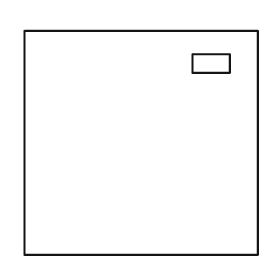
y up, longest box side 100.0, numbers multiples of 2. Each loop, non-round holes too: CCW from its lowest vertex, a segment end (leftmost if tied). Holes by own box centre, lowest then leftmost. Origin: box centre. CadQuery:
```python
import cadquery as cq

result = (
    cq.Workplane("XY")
    .moveTo(-50.0, -48.0)
    .lineTo(50.0, -48.0)
    .lineTo(50.0, 48.0)
    .lineTo(-50.0, 48.0)
    .close()
    .moveTo(22.0, 30.0)
    .lineTo(38.0, 30.0)
    .lineTo(38.0, 38.0)
    .lineTo(22.0, 38.0)
    .close()
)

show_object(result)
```